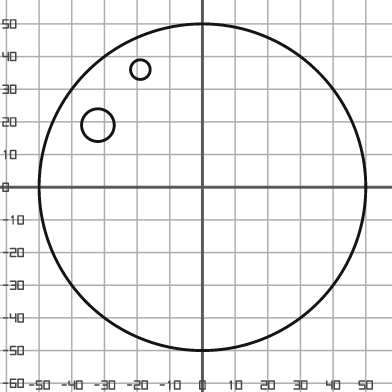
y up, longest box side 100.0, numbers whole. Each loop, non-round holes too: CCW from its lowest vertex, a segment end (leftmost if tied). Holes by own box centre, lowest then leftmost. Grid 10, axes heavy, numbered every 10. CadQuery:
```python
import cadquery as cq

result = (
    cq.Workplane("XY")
    .moveTo(0.0, 0.0)
    .circle(50.0)
    .moveTo(-32.0, 19.0)
    .circle(5.0)
    .moveTo(-19.0, 36.0)
    .circle(3.0)
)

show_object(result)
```